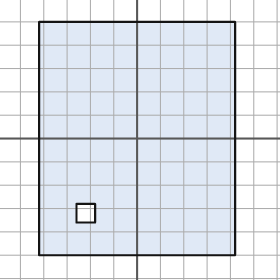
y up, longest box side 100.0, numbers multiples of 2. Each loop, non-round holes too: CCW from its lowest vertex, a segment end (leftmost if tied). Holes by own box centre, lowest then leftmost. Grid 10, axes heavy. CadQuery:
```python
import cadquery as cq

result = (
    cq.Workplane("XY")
    .moveTo(-42.0, -50.0)
    .lineTo(42.0, -50.0)
    .lineTo(42.0, 50.0)
    .lineTo(-42.0, 50.0)
    .close()
    .moveTo(-26.0, -36.0)
    .lineTo(-18.0, -36.0)
    .lineTo(-18.0, -28.0)
    .lineTo(-26.0, -28.0)
    .close()
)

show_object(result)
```